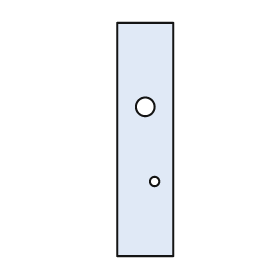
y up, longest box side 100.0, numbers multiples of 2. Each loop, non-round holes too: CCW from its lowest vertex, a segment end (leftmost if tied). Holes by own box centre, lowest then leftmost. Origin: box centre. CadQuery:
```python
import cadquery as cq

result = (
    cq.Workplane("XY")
    .moveTo(-12.0, -50.0)
    .lineTo(12.0, -50.0)
    .lineTo(12.0, 50.0)
    .lineTo(-12.0, 50.0)
    .close()
    .moveTo(4.0, -18.0)
    .circle(2.0)
    .moveTo(0.0, 14.0)
    .circle(4.0)
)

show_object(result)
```